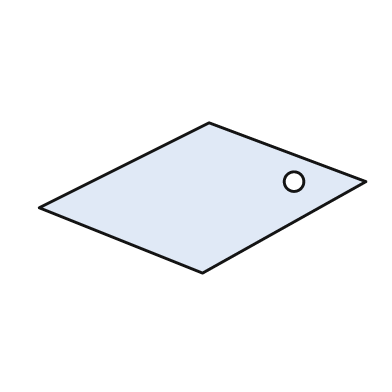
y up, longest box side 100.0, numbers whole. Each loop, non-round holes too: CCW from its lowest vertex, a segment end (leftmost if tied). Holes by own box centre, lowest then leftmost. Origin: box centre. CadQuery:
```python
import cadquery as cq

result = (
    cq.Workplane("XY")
    .moveTo(0.0, -23.0)
    .lineTo(50.0, 5.0)
    .lineTo(2.0, 23.0)
    .lineTo(-50.0, -3.0)
    .close()
    .moveTo(28.0, 5.0)
    .circle(3.0)
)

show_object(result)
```